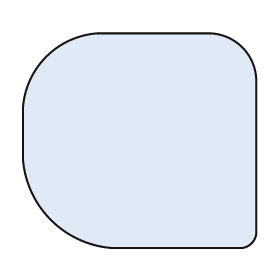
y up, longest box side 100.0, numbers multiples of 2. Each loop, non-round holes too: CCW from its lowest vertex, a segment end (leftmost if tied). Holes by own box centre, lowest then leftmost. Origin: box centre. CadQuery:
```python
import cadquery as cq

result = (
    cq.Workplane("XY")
    .moveTo(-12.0, -46.0)
    .lineTo(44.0, -46.0)
    .threePointArc((48.0, -44.0), (50.0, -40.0))
    .lineTo(50.0, 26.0)
    .threePointArc((44.0, 40.0), (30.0, 46.0))
    .lineTo(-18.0, 46.0)
    .threePointArc((-40.0, 36.0), (-50.0, 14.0))
    .lineTo(-50.0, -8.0)
    .threePointArc((-38.0, -34.0), (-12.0, -46.0))
    .close()
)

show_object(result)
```